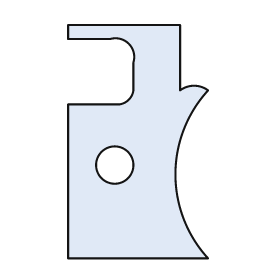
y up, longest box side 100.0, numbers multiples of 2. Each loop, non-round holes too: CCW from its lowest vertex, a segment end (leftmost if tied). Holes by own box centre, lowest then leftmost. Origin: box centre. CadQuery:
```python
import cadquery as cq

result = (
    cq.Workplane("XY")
    .moveTo(-30.0, -50.0)
    .lineTo(30.0, -50.0)
    .threePointArc((16.0, -14.0), (30.0, 22.0))
    .threePointArc((24.0, 24.0), (18.0, 22.0))
    .lineTo(18.0, 50.0)
    .lineTo(-30.0, 50.0)
    .lineTo(-30.0, 44.0)
    .lineTo(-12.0, 44.0)
    .threePointArc((-4.0, 42.0), (-2.0, 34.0))
    .lineTo(-2.0, 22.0)
    .threePointArc((-4.0, 18.0), (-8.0, 16.0))
    .lineTo(-30.0, 16.0)
    .close()
    .moveTo(-10.0, -10.0)
    .circle(8.0)
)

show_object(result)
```